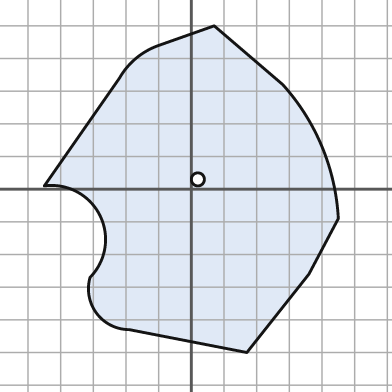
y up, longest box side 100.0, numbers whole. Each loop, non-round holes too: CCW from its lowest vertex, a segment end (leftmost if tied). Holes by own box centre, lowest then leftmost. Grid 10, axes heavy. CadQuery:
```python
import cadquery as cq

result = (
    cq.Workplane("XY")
    .moveTo(17.0, -50.0)
    .lineTo(36.0, -26.0)
    .lineTo(45.0, -9.0)
    .threePointArc((40.0, 13.0), (28.0, 32.0))
    .lineTo(7.0, 50.0)
    .lineTo(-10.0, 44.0)
    .threePointArc((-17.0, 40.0), (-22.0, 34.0))
    .lineTo(-45.0, 1.0)
    .threePointArc((-28.0, -8.0), (-31.0, -27.0))
    .threePointArc((-29.0, -38.0), (-19.0, -43.0))
    .close()
    .moveTo(2.0, 3.0)
    .circle(2.0)
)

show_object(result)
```